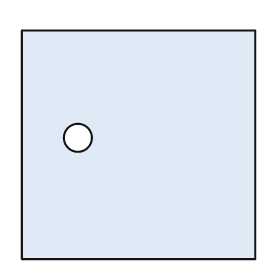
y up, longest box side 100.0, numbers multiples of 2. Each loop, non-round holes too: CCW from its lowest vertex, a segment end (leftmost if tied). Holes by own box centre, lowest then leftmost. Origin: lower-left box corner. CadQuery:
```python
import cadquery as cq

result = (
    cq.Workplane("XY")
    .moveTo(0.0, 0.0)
    .lineTo(100.0, 0.0)
    .lineTo(100.0, 98.0)
    .lineTo(0.0, 98.0)
    .close()
    .moveTo(24.0, 52.0)
    .circle(6.0)
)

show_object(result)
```